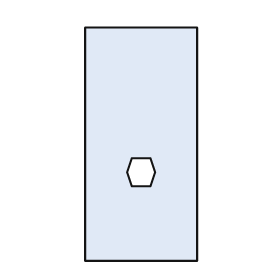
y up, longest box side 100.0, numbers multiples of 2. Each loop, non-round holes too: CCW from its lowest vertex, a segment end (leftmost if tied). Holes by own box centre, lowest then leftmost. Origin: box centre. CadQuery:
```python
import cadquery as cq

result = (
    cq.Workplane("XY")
    .moveTo(-24.0, -50.0)
    .lineTo(24.0, -50.0)
    .lineTo(24.0, 50.0)
    .lineTo(-24.0, 50.0)
    .close()
    .moveTo(-4.0, -18.0)
    .lineTo(4.0, -18.0)
    .lineTo(6.0, -12.0)
    .lineTo(4.0, -6.0)
    .lineTo(-4.0, -6.0)
    .lineTo(-6.0, -12.0)
    .close()
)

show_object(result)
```